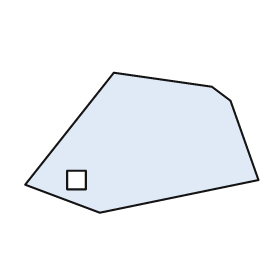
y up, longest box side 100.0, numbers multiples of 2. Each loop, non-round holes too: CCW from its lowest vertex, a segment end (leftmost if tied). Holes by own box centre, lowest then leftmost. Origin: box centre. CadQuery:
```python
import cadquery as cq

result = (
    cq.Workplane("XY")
    .moveTo(-18.0, -30.0)
    .lineTo(50.0, -16.0)
    .lineTo(38.0, 18.0)
    .lineTo(30.0, 24.0)
    .lineTo(-12.0, 30.0)
    .lineTo(-50.0, -18.0)
    .close()
    .moveTo(-32.0, -20.0)
    .lineTo(-24.0, -20.0)
    .lineTo(-24.0, -12.0)
    .lineTo(-32.0, -12.0)
    .close()
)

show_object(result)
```